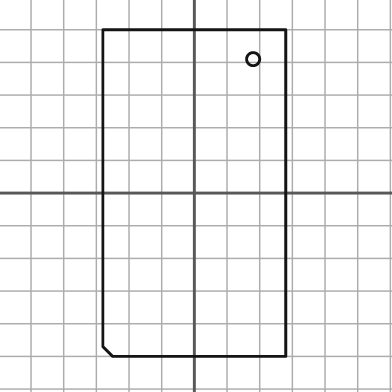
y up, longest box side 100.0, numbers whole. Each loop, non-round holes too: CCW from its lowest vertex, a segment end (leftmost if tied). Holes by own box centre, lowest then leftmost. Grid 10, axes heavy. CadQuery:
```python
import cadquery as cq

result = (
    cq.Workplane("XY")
    .moveTo(-25.0, -50.0)
    .lineTo(28.0, -50.0)
    .lineTo(28.0, 50.0)
    .lineTo(-28.0, 50.0)
    .lineTo(-28.0, -47.0)
    .close()
    .moveTo(18.0, 41.0)
    .circle(2.0)
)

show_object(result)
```